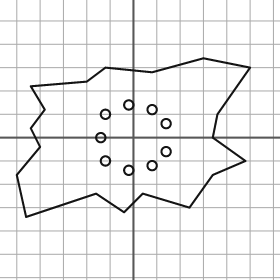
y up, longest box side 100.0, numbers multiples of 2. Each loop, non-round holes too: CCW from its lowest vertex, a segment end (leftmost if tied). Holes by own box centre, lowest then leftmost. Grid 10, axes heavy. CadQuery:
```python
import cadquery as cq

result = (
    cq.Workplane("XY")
    .moveTo(-46.0, -34.0)
    .lineTo(-16.0, -24.0)
    .lineTo(-4.0, -32.0)
    .lineTo(4.0, -24.0)
    .lineTo(24.0, -30.0)
    .lineTo(34.0, -16.0)
    .lineTo(48.0, -10.0)
    .lineTo(34.0, 0.0)
    .lineTo(36.0, 10.0)
    .lineTo(50.0, 30.0)
    .lineTo(30.0, 34.0)
    .lineTo(8.0, 28.0)
    .lineTo(-12.0, 30.0)
    .lineTo(-20.0, 24.0)
    .lineTo(-44.0, 22.0)
    .lineTo(-38.0, 12.0)
    .lineTo(-44.0, 4.0)
    .lineTo(-40.0, -4.0)
    .lineTo(-50.0, -16.0)
    .close()
    .moveTo(-2.0, -14.0)
    .circle(2.0)
    .moveTo(8.0, -12.0)
    .circle(2.0)
    .moveTo(-12.0, -10.0)
    .circle(2.0)
    .moveTo(14.0, -6.0)
    .circle(2.0)
    .moveTo(-14.0, 0.0)
    .circle(2.0)
    .moveTo(14.0, 6.0)
    .circle(2.0)
    .moveTo(-12.0, 10.0)
    .circle(2.0)
    .moveTo(8.0, 12.0)
    .circle(2.0)
    .moveTo(-2.0, 14.0)
    .circle(2.0)
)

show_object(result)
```